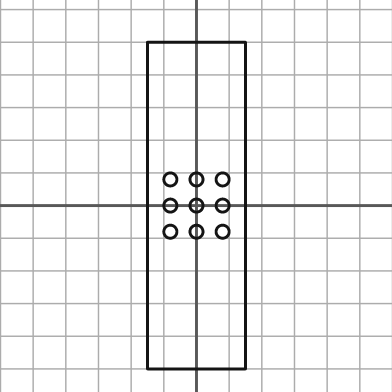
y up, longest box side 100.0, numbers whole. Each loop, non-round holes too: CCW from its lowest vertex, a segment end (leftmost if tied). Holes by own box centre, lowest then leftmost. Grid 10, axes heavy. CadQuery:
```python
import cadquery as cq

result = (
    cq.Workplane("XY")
    .moveTo(-15.0, -50.0)
    .lineTo(15.0, -50.0)
    .lineTo(15.0, 50.0)
    .lineTo(-15.0, 50.0)
    .close()
    .moveTo(-8.0, -8.0)
    .circle(2.0)
    .moveTo(0.0, -8.0)
    .circle(2.0)
    .moveTo(8.0, -8.0)
    .circle(2.0)
    .moveTo(-8.0, 0.0)
    .circle(2.0)
    .moveTo(0.0, 0.0)
    .circle(2.0)
    .moveTo(8.0, 0.0)
    .circle(2.0)
    .moveTo(-8.0, 8.0)
    .circle(2.0)
    .moveTo(0.0, 8.0)
    .circle(2.0)
    .moveTo(8.0, 8.0)
    .circle(2.0)
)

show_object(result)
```